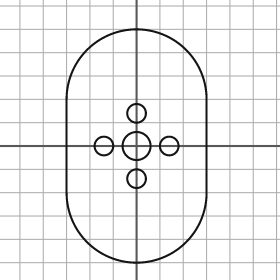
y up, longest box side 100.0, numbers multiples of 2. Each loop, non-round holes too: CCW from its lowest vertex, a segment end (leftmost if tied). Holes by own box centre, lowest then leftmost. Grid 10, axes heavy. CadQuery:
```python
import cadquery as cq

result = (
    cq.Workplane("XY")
    .moveTo(-30.0, -20.0)
    .threePointArc((0.0, -50.0), (30.0, -20.0))
    .lineTo(30.0, 20.0)
    .threePointArc((0.0, 50.0), (-30.0, 20.0))
    .close()
    .moveTo(0.0, -14.0)
    .circle(4.0)
    .moveTo(-14.0, 0.0)
    .circle(4.0)
    .moveTo(0.0, 0.0)
    .circle(6.0)
    .moveTo(14.0, 0.0)
    .circle(4.0)
    .moveTo(0.0, 14.0)
    .circle(4.0)
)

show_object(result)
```